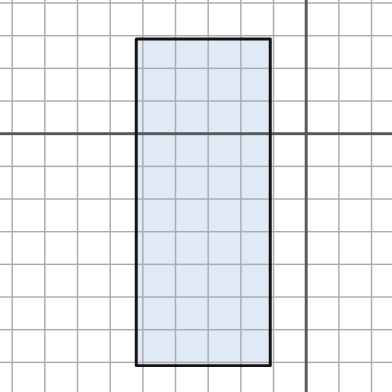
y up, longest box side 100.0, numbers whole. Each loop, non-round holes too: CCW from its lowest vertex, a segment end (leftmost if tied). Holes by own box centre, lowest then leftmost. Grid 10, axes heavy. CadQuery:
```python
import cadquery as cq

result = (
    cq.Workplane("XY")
    .moveTo(-52.0, -71.0)
    .lineTo(-11.0, -71.0)
    .lineTo(-11.0, 29.0)
    .lineTo(-52.0, 29.0)
    .close()
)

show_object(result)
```